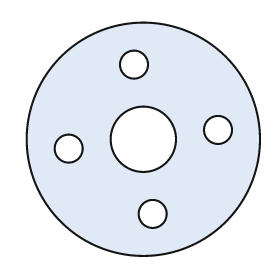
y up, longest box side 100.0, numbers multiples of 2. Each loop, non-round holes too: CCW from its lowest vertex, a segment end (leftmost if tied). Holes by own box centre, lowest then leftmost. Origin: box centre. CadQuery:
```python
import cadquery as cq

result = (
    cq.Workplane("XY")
    .moveTo(0.0, 0.0)
    .circle(50.0)
    .moveTo(4.0, -32.0)
    .circle(6.0)
    .moveTo(-32.0, -4.0)
    .circle(6.0)
    .moveTo(0.0, 0.0)
    .circle(14.0)
    .moveTo(32.0, 4.0)
    .circle(6.0)
    .moveTo(-4.0, 32.0)
    .circle(6.0)
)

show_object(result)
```